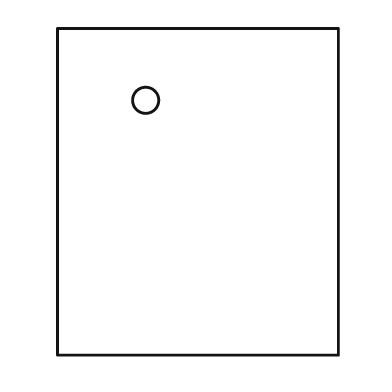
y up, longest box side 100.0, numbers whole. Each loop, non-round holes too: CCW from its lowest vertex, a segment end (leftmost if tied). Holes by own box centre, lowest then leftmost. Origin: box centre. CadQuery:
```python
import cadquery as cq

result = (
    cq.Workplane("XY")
    .moveTo(-43.0, -50.0)
    .lineTo(43.0, -50.0)
    .lineTo(43.0, 50.0)
    .lineTo(-43.0, 50.0)
    .close()
    .moveTo(-16.0, 28.0)
    .circle(4.0)
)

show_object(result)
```